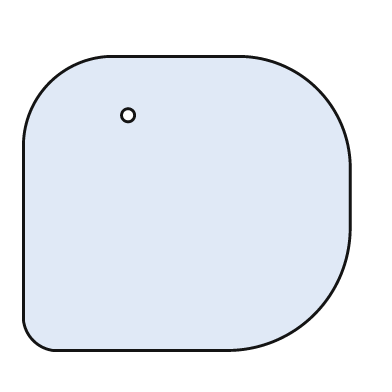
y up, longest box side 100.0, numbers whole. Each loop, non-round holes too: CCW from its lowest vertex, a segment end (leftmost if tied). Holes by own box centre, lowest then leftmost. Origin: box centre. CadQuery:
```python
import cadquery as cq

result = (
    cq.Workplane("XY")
    .moveTo(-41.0, -45.0)
    .lineTo(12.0, -45.0)
    .threePointArc((39.0, -34.0), (50.0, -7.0))
    .lineTo(50.0, 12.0)
    .threePointArc((40.0, 35.0), (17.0, 45.0))
    .lineTo(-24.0, 45.0)
    .threePointArc((-42.0, 37.0), (-50.0, 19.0))
    .lineTo(-50.0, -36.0)
    .threePointArc((-47.0, -42.0), (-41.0, -45.0))
    .close()
    .moveTo(-18.0, 27.0)
    .circle(2.0)
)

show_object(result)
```